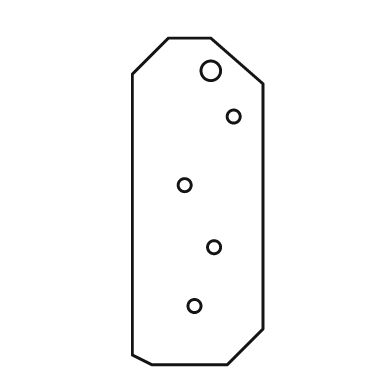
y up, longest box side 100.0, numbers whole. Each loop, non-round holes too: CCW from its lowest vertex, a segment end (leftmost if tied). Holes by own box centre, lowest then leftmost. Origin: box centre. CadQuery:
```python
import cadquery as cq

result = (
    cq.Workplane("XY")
    .moveTo(-14.0, -50.0)
    .lineTo(9.0, -50.0)
    .lineTo(20.0, -39.0)
    .lineTo(20.0, 36.0)
    .lineTo(4.0, 50.0)
    .lineTo(-9.0, 50.0)
    .lineTo(-20.0, 39.0)
    .lineTo(-20.0, -47.0)
    .close()
    .moveTo(-1.0, -32.0)
    .circle(2.0)
    .moveTo(5.0, -14.0)
    .circle(2.0)
    .moveTo(-4.0, 5.0)
    .circle(2.0)
    .moveTo(11.0, 26.0)
    .circle(2.0)
    .moveTo(4.0, 40.0)
    .circle(3.0)
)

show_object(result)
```